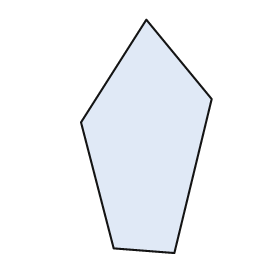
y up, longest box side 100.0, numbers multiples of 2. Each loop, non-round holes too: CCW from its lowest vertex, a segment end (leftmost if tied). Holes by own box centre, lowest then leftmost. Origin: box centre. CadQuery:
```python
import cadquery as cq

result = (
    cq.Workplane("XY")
    .moveTo(12.0, -50.0)
    .lineTo(28.0, 16.0)
    .lineTo(0.0, 50.0)
    .lineTo(-28.0, 6.0)
    .lineTo(-14.0, -48.0)
    .close()
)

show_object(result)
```